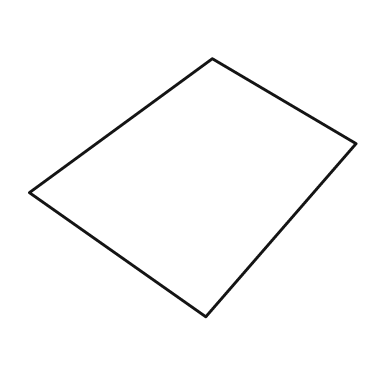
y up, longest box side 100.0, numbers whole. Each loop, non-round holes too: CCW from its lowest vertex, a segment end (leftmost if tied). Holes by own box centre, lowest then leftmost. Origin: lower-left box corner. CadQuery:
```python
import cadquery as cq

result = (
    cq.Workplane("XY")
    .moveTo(54.0, 0.0)
    .lineTo(100.0, 53.0)
    .lineTo(56.0, 79.0)
    .lineTo(0.0, 38.0)
    .close()
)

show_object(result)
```